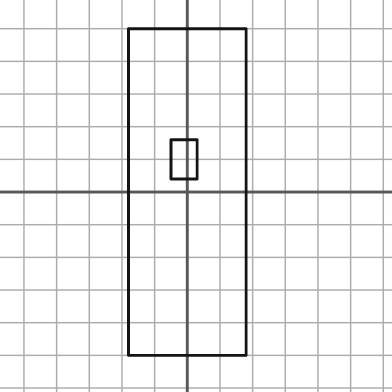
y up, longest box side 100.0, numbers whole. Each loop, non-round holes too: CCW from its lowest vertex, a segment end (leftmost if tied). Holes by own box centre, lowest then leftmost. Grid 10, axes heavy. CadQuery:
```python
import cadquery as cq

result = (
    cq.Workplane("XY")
    .moveTo(-18.0, -50.0)
    .lineTo(18.0, -50.0)
    .lineTo(18.0, 50.0)
    .lineTo(-18.0, 50.0)
    .close()
    .moveTo(-5.0, 4.0)
    .lineTo(3.0, 4.0)
    .lineTo(3.0, 16.0)
    .lineTo(-5.0, 16.0)
    .close()
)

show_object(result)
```